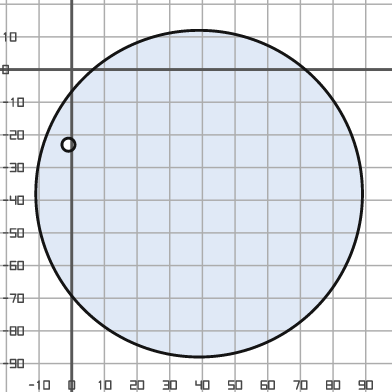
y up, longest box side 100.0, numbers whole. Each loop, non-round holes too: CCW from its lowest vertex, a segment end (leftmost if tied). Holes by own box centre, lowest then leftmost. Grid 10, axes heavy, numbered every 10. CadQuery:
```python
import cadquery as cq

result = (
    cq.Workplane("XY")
    .moveTo(39.0, -38.0)
    .circle(50.0)
    .moveTo(-1.0, -23.0)
    .circle(2.0)
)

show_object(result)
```